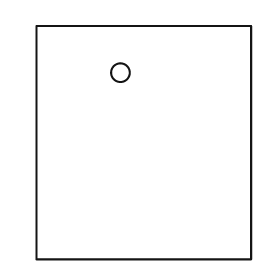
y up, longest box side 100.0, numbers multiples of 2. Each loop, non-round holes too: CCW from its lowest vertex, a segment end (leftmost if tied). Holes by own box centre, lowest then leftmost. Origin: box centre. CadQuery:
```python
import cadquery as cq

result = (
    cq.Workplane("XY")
    .moveTo(-46.0, -50.0)
    .lineTo(46.0, -50.0)
    .lineTo(46.0, 50.0)
    .lineTo(-46.0, 50.0)
    .close()
    .moveTo(-10.0, 30.0)
    .circle(4.0)
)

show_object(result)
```